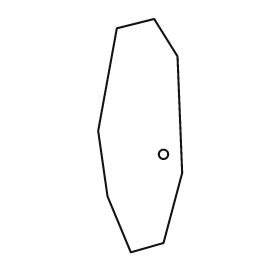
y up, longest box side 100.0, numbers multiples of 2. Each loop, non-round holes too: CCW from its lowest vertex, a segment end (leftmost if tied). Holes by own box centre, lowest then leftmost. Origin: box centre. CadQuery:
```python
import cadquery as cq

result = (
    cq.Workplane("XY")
    .moveTo(-4.0, -50.0)
    .lineTo(10.0, -46.0)
    .lineTo(18.0, -16.0)
    .lineTo(16.0, 34.0)
    .lineTo(6.0, 50.0)
    .lineTo(-10.0, 46.0)
    .lineTo(-18.0, 2.0)
    .lineTo(-14.0, -26.0)
    .close()
    .moveTo(10.0, -8.0)
    .circle(2.0)
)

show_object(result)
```